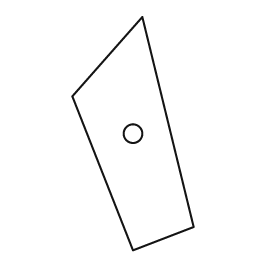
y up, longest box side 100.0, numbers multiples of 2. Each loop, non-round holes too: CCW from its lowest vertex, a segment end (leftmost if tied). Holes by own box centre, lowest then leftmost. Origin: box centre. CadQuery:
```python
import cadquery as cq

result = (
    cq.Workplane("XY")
    .moveTo(0.0, -50.0)
    .lineTo(26.0, -40.0)
    .lineTo(4.0, 50.0)
    .lineTo(-26.0, 16.0)
    .close()
    .moveTo(0.0, 0.0)
    .circle(4.0)
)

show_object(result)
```